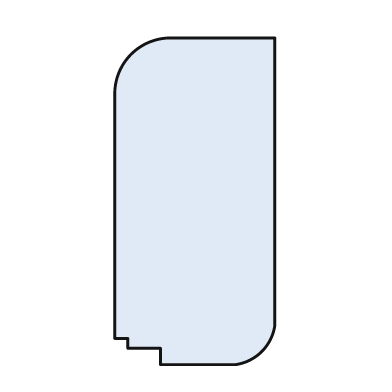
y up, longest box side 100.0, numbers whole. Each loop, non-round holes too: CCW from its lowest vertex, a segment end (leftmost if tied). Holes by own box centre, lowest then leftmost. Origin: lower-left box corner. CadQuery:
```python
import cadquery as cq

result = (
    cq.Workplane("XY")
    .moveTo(14.0, 0.0)
    .lineTo(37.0, 0.0)
    .threePointArc((45.0, 4.0), (49.0, 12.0))
    .lineTo(49.0, 100.0)
    .lineTo(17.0, 100.0)
    .threePointArc((5.0, 95.0), (0.0, 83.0))
    .lineTo(0.0, 8.0)
    .lineTo(4.0, 8.0)
    .lineTo(4.0, 5.0)
    .lineTo(14.0, 5.0)
    .close()
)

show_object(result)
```